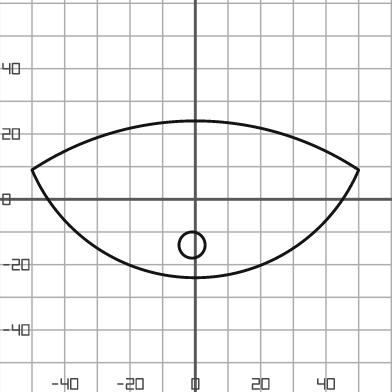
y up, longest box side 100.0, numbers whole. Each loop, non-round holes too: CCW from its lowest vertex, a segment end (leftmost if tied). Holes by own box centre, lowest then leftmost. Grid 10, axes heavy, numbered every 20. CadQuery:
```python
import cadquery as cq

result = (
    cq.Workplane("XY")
    .moveTo(-50.0, 9.0)
    .threePointArc((0.0, -24.0), (50.0, 9.0))
    .threePointArc((0.0, 24.0), (-50.0, 9.0))
    .close()
    .moveTo(-1.0, -14.0)
    .circle(4.0)
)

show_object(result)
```